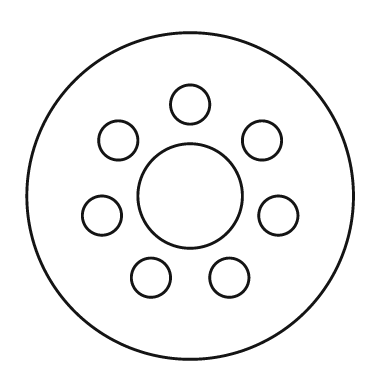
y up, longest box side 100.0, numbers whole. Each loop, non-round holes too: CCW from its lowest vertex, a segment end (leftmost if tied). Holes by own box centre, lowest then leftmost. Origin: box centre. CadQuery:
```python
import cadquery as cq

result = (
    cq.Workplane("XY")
    .moveTo(0.0, 0.0)
    .circle(50.0)
    .moveTo(-12.0, -25.0)
    .circle(6.0)
    .moveTo(12.0, -25.0)
    .circle(6.0)
    .moveTo(-27.0, -6.0)
    .circle(6.0)
    .moveTo(27.0, -6.0)
    .circle(6.0)
    .moveTo(0.0, 0.0)
    .circle(16.0)
    .moveTo(-22.0, 17.0)
    .circle(6.0)
    .moveTo(22.0, 17.0)
    .circle(6.0)
    .moveTo(0.0, 28.0)
    .circle(6.0)
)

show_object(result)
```